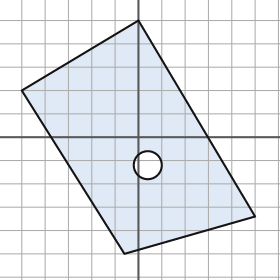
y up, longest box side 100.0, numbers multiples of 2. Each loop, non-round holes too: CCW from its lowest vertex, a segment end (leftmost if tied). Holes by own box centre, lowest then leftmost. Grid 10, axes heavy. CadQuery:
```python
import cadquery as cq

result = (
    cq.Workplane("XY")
    .moveTo(-6.0, -50.0)
    .lineTo(50.0, -34.0)
    .lineTo(0.0, 50.0)
    .lineTo(-50.0, 20.0)
    .close()
    .moveTo(4.0, -12.0)
    .circle(6.0)
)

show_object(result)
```